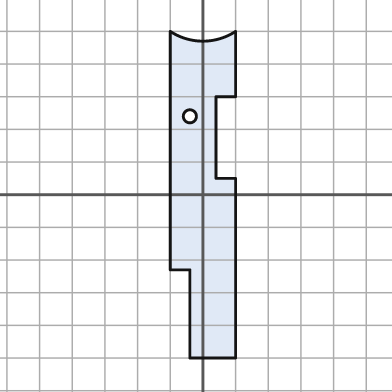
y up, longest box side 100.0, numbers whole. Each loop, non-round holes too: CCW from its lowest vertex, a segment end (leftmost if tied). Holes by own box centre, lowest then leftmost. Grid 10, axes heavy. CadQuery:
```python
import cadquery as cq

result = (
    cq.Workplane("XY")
    .moveTo(-4.0, -50.0)
    .lineTo(10.0, -50.0)
    .lineTo(10.0, 5.0)
    .lineTo(4.0, 5.0)
    .lineTo(4.0, 30.0)
    .lineTo(10.0, 30.0)
    .lineTo(10.0, 50.0)
    .threePointArc((0.0, 47.0), (-10.0, 50.0))
    .lineTo(-10.0, -23.0)
    .lineTo(-4.0, -23.0)
    .close()
    .moveTo(-4.0, 24.0)
    .circle(2.0)
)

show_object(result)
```